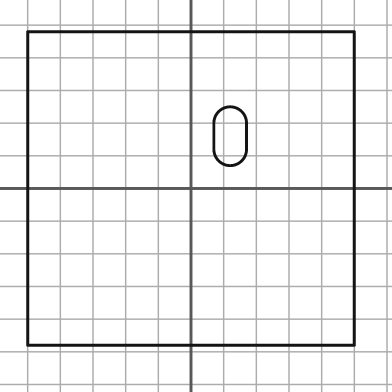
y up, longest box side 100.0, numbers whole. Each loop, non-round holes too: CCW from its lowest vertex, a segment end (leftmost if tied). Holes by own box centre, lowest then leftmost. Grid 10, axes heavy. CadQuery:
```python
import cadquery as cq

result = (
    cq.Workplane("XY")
    .moveTo(-50.0, -48.0)
    .lineTo(50.0, -48.0)
    .lineTo(50.0, 48.0)
    .lineTo(-50.0, 48.0)
    .close()
    .moveTo(7.0, 12.0)
    .threePointArc((12.0, 7.0), (17.0, 12.0))
    .lineTo(17.0, 20.0)
    .threePointArc((12.0, 25.0), (7.0, 20.0))
    .close()
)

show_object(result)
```